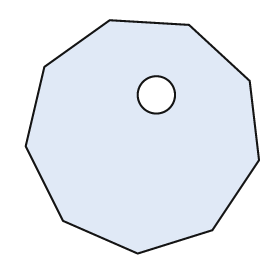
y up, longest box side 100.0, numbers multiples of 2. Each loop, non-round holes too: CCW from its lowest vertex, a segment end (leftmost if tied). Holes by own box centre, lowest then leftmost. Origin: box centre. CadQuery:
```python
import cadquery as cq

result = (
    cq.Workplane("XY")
    .moveTo(-2.0, -50.0)
    .lineTo(30.0, -40.0)
    .lineTo(50.0, -10.0)
    .lineTo(46.0, 24.0)
    .lineTo(20.0, 48.0)
    .lineTo(-14.0, 50.0)
    .lineTo(-42.0, 30.0)
    .lineTo(-50.0, -4.0)
    .lineTo(-34.0, -36.0)
    .close()
    .moveTo(6.0, 18.0)
    .circle(8.0)
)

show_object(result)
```